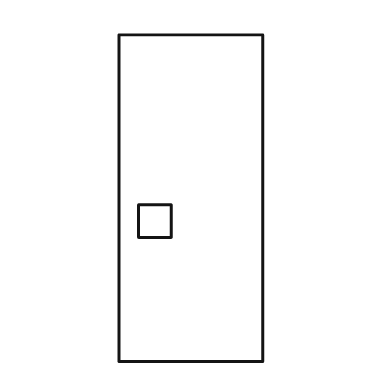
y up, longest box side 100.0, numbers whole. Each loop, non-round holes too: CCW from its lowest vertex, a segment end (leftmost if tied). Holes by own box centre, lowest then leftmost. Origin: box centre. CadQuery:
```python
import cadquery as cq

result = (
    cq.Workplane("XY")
    .moveTo(-22.0, -50.0)
    .lineTo(22.0, -50.0)
    .lineTo(22.0, 50.0)
    .lineTo(-22.0, 50.0)
    .close()
    .moveTo(-16.0, -12.0)
    .lineTo(-6.0, -12.0)
    .lineTo(-6.0, -2.0)
    .lineTo(-16.0, -2.0)
    .close()
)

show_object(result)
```